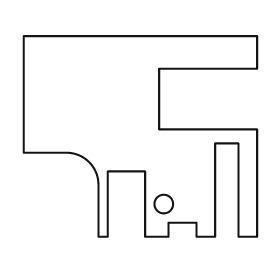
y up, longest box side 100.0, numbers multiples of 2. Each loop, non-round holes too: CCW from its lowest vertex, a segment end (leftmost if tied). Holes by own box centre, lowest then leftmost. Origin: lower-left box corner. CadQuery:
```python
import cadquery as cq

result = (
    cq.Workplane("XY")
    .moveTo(32.0, 0.0)
    .lineTo(36.0, 0.0)
    .lineTo(36.0, 28.0)
    .lineTo(52.0, 28.0)
    .lineTo(52.0, 0.0)
    .lineTo(62.0, 0.0)
    .lineTo(62.0, 6.0)
    .lineTo(74.0, 6.0)
    .lineTo(74.0, 0.0)
    .lineTo(82.0, 0.0)
    .lineTo(82.0, 40.0)
    .lineTo(92.0, 40.0)
    .lineTo(92.0, 0.0)
    .lineTo(100.0, 0.0)
    .lineTo(100.0, 46.0)
    .lineTo(58.0, 46.0)
    .lineTo(58.0, 72.0)
    .lineTo(100.0, 72.0)
    .lineTo(100.0, 86.0)
    .lineTo(0.0, 86.0)
    .lineTo(0.0, 36.0)
    .lineTo(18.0, 36.0)
    .threePointArc((28.0, 32.0), (32.0, 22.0))
    .close()
    .moveTo(60.0, 14.0)
    .circle(4.0)
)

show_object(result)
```